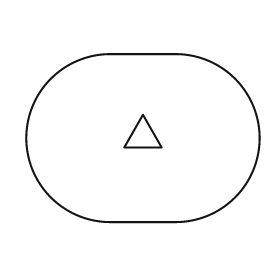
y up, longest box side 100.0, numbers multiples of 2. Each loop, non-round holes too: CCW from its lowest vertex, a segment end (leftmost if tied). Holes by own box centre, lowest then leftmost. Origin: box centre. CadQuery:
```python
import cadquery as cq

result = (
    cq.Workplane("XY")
    .moveTo(-14.0, -36.0)
    .lineTo(14.0, -36.0)
    .threePointArc((50.0, 0.0), (14.0, 36.0))
    .lineTo(-14.0, 36.0)
    .threePointArc((-50.0, 0.0), (-14.0, -36.0))
    .close()
    .moveTo(-8.0, -4.0)
    .lineTo(8.0, -4.0)
    .lineTo(0.0, 10.0)
    .close()
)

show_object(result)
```